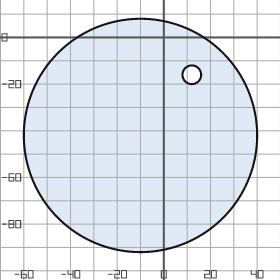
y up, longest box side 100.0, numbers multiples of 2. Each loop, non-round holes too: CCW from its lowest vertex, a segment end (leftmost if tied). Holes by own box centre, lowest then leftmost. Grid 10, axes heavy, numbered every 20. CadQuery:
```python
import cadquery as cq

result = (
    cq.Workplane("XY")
    .moveTo(-10.0, -42.0)
    .circle(50.0)
    .moveTo(12.0, -16.0)
    .circle(4.0)
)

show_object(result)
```